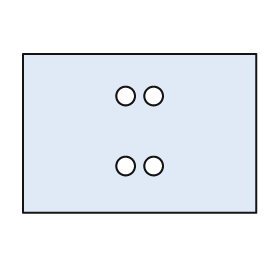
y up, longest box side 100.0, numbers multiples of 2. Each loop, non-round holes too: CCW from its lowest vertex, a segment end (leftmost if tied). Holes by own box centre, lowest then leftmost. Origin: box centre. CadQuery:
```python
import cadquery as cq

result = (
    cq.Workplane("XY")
    .moveTo(-50.0, -34.0)
    .lineTo(50.0, -34.0)
    .lineTo(50.0, 34.0)
    .lineTo(-50.0, 34.0)
    .close()
    .moveTo(-6.0, -14.0)
    .circle(4.0)
    .moveTo(6.0, -14.0)
    .circle(4.0)
    .moveTo(-6.0, 16.0)
    .circle(4.0)
    .moveTo(6.0, 16.0)
    .circle(4.0)
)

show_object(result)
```